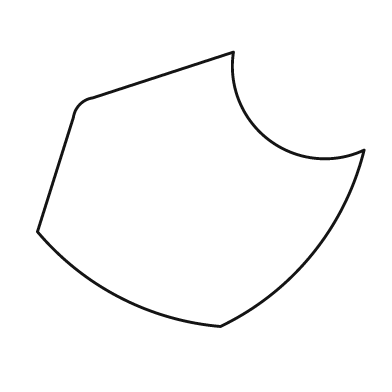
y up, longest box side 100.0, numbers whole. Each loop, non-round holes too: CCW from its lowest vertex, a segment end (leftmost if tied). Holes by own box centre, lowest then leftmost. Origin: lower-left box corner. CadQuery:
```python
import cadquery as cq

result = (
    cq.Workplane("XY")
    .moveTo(56.0, 0.0)
    .threePointArc((84.0, 22.0), (100.0, 54.0))
    .threePointArc((71.0, 57.0), (60.0, 84.0))
    .lineTo(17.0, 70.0)
    .threePointArc((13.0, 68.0), (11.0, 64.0))
    .lineTo(0.0, 29.0)
    .threePointArc((25.0, 9.0), (56.0, 0.0))
    .close()
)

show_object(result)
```